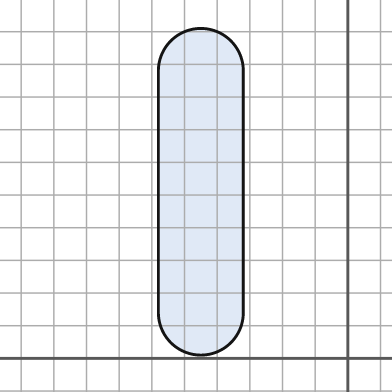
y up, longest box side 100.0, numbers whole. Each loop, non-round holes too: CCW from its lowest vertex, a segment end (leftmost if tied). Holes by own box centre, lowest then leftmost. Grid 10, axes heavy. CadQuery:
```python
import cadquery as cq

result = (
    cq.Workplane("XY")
    .moveTo(-58.0, 14.0)
    .threePointArc((-45.0, 1.0), (-32.0, 14.0))
    .lineTo(-32.0, 88.0)
    .threePointArc((-45.0, 101.0), (-58.0, 88.0))
    .close()
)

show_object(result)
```